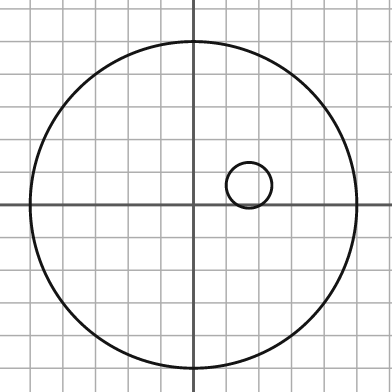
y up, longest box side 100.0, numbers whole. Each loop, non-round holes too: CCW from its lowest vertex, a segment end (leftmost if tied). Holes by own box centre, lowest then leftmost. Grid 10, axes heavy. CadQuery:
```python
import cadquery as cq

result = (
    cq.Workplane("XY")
    .moveTo(0.0, 0.0)
    .circle(50.0)
    .moveTo(17.0, 6.0)
    .circle(7.0)
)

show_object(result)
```